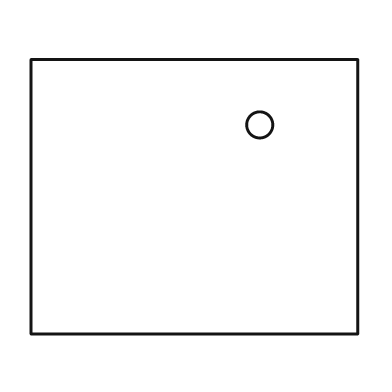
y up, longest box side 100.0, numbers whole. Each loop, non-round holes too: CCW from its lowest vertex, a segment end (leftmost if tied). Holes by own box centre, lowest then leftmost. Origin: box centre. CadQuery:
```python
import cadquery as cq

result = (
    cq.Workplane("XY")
    .moveTo(-50.0, -42.0)
    .lineTo(50.0, -42.0)
    .lineTo(50.0, 42.0)
    .lineTo(-50.0, 42.0)
    .close()
    .moveTo(20.0, 22.0)
    .circle(4.0)
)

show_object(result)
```